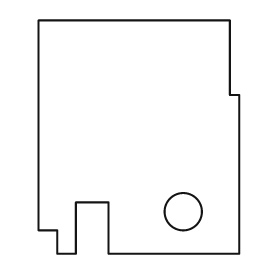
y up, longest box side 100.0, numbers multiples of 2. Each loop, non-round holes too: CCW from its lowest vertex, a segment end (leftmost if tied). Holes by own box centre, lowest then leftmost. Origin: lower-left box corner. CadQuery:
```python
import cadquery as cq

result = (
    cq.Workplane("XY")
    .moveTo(8.0, 0.0)
    .lineTo(16.0, 0.0)
    .lineTo(16.0, 22.0)
    .lineTo(30.0, 22.0)
    .lineTo(30.0, 0.0)
    .lineTo(86.0, 0.0)
    .lineTo(86.0, 68.0)
    .lineTo(82.0, 68.0)
    .lineTo(82.0, 100.0)
    .lineTo(0.0, 100.0)
    .lineTo(0.0, 10.0)
    .lineTo(8.0, 10.0)
    .close()
    .moveTo(62.0, 18.0)
    .circle(8.0)
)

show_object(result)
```